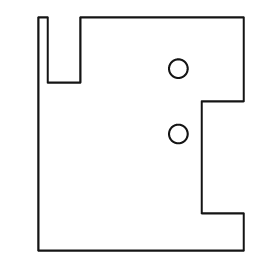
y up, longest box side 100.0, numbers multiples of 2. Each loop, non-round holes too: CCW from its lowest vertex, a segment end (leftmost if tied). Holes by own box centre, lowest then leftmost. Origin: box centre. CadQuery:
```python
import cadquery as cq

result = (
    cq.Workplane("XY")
    .moveTo(-44.0, -50.0)
    .lineTo(44.0, -50.0)
    .lineTo(44.0, -34.0)
    .lineTo(26.0, -34.0)
    .lineTo(26.0, 14.0)
    .lineTo(44.0, 14.0)
    .lineTo(44.0, 50.0)
    .lineTo(-26.0, 50.0)
    .lineTo(-26.0, 22.0)
    .lineTo(-40.0, 22.0)
    .lineTo(-40.0, 50.0)
    .lineTo(-44.0, 50.0)
    .close()
    .moveTo(16.0, 0.0)
    .circle(4.0)
    .moveTo(16.0, 28.0)
    .circle(4.0)
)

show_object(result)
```